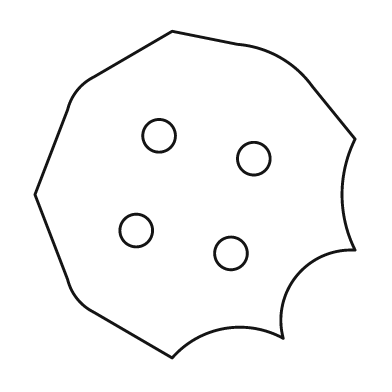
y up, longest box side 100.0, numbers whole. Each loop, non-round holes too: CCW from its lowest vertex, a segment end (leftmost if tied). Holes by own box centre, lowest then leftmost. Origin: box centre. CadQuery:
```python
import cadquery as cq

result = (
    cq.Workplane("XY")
    .moveTo(-7.0, -50.0)
    .threePointArc((9.0, -41.0), (27.0, -44.0))
    .threePointArc((31.0, -25.0), (49.0, -17.0))
    .threePointArc((45.0, 0.0), (49.0, 17.0))
    .lineTo(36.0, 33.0)
    .threePointArc((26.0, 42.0), (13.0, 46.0))
    .lineTo(-7.0, 50.0)
    .lineTo(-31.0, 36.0)
    .threePointArc((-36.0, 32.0), (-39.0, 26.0))
    .lineTo(-49.0, 0.0)
    .lineTo(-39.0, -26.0)
    .threePointArc((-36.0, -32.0), (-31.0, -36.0))
    .close()
    .moveTo(11.0, -18.0)
    .circle(5.0)
    .moveTo(-18.0, -11.0)
    .circle(5.0)
    .moveTo(18.0, 11.0)
    .circle(5.0)
    .moveTo(-11.0, 18.0)
    .circle(5.0)
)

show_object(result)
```